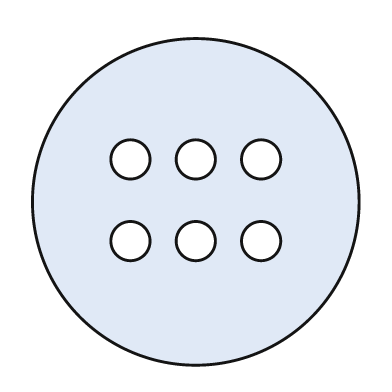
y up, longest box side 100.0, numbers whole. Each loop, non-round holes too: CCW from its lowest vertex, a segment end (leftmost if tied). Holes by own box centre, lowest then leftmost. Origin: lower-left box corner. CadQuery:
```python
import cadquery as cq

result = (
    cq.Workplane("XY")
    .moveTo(50.0, 50.0)
    .circle(50.0)
    .moveTo(30.0, 38.0)
    .circle(6.0)
    .moveTo(50.0, 38.0)
    .circle(6.0)
    .moveTo(70.0, 38.0)
    .circle(6.0)
    .moveTo(30.0, 63.0)
    .circle(6.0)
    .moveTo(50.0, 63.0)
    .circle(6.0)
    .moveTo(70.0, 63.0)
    .circle(6.0)
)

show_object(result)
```